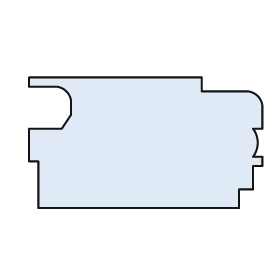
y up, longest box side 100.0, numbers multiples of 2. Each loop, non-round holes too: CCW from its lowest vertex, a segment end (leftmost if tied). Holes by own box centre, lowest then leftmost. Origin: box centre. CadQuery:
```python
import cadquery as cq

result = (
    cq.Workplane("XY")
    .moveTo(-46.0, -28.0)
    .lineTo(40.0, -28.0)
    .lineTo(40.0, -20.0)
    .lineTo(46.0, -20.0)
    .lineTo(46.0, -10.0)
    .lineTo(50.0, -10.0)
    .lineTo(50.0, -6.0)
    .lineTo(46.0, -6.0)
    .threePointArc((48.0, 0.0), (46.0, 6.0))
    .lineTo(50.0, 6.0)
    .lineTo(50.0, 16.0)
    .threePointArc((48.0, 20.0), (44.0, 22.0))
    .lineTo(24.0, 22.0)
    .lineTo(24.0, 28.0)
    .lineTo(-50.0, 28.0)
    .lineTo(-50.0, 24.0)
    .lineTo(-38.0, 24.0)
    .threePointArc((-34.0, 22.0), (-32.0, 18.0))
    .lineTo(-32.0, 12.0)
    .lineTo(-36.0, 6.0)
    .lineTo(-50.0, 6.0)
    .lineTo(-50.0, -8.0)
    .lineTo(-46.0, -8.0)
    .close()
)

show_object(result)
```